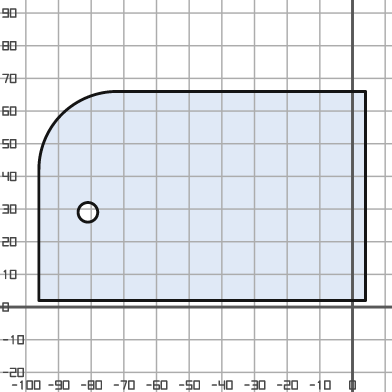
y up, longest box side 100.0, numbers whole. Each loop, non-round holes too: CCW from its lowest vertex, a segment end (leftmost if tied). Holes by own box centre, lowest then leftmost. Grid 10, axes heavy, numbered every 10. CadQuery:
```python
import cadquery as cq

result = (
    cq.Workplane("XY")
    .moveTo(-96.0, 2.0)
    .lineTo(4.0, 2.0)
    .lineTo(4.0, 66.0)
    .lineTo(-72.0, 66.0)
    .threePointArc((-89.0, 59.0), (-96.0, 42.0))
    .close()
    .moveTo(-81.0, 29.0)
    .circle(3.0)
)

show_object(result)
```